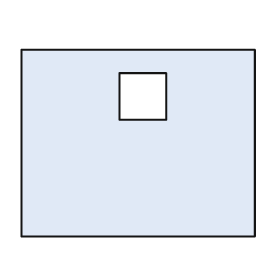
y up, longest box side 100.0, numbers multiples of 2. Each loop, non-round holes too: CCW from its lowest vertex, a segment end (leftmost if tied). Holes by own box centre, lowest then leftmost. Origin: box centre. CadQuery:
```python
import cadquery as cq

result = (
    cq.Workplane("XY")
    .moveTo(-50.0, -40.0)
    .lineTo(50.0, -40.0)
    .lineTo(50.0, 40.0)
    .lineTo(-50.0, 40.0)
    .close()
    .moveTo(-8.0, 10.0)
    .lineTo(12.0, 10.0)
    .lineTo(12.0, 30.0)
    .lineTo(-8.0, 30.0)
    .close()
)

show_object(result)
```